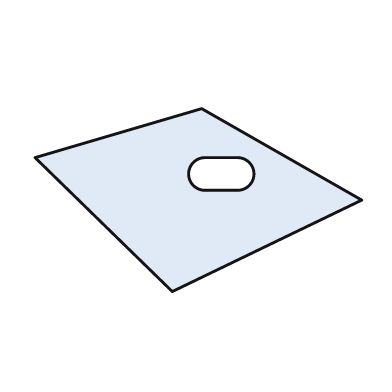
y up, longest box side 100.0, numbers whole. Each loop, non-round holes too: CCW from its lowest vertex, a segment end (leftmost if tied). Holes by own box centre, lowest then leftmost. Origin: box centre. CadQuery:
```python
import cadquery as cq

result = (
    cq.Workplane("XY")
    .moveTo(-8.0, -28.0)
    .lineTo(50.0, 0.0)
    .lineTo(1.0, 28.0)
    .lineTo(-50.0, 13.0)
    .close()
    .moveTo(2.0, 3.0)
    .lineTo(12.0, 3.0)
    .threePointArc((17.0, 8.0), (12.0, 13.0))
    .lineTo(2.0, 13.0)
    .threePointArc((-3.0, 8.0), (2.0, 3.0))
    .close()
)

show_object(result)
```